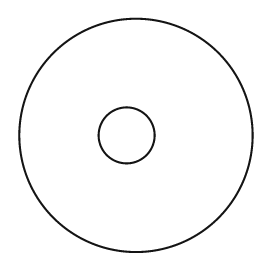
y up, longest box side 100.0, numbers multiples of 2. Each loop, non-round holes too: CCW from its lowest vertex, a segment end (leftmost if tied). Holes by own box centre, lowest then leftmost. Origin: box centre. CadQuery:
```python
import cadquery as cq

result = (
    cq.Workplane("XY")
    .moveTo(0.0, 0.0)
    .circle(50.0)
    .moveTo(-4.0, 0.0)
    .circle(12.0)
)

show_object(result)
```